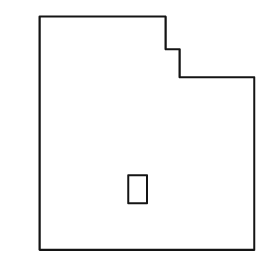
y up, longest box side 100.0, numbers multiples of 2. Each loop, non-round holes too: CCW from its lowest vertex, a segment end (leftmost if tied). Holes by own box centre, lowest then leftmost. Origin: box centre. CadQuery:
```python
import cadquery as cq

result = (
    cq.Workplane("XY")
    .moveTo(-46.0, -50.0)
    .lineTo(46.0, -50.0)
    .lineTo(46.0, 24.0)
    .lineTo(14.0, 24.0)
    .lineTo(14.0, 36.0)
    .lineTo(8.0, 36.0)
    .lineTo(8.0, 50.0)
    .lineTo(-46.0, 50.0)
    .close()
    .moveTo(-8.0, -30.0)
    .lineTo(0.0, -30.0)
    .lineTo(0.0, -18.0)
    .lineTo(-8.0, -18.0)
    .close()
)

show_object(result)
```